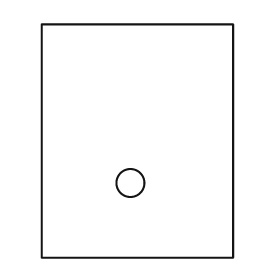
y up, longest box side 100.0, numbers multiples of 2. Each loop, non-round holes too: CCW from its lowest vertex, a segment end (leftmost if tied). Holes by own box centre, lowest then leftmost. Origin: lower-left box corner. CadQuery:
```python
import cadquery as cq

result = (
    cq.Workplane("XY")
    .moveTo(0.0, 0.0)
    .lineTo(82.0, 0.0)
    .lineTo(82.0, 100.0)
    .lineTo(0.0, 100.0)
    .close()
    .moveTo(38.0, 32.0)
    .circle(6.0)
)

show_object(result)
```